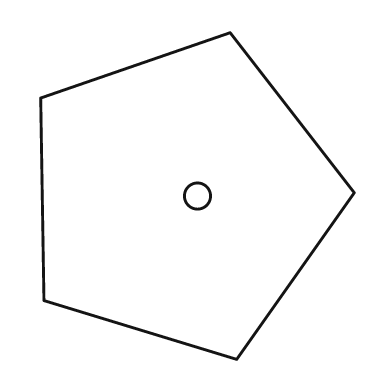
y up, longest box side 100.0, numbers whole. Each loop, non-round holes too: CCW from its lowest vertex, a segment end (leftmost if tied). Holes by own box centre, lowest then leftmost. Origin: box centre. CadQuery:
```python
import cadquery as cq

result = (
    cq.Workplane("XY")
    .moveTo(12.0, -50.0)
    .lineTo(48.0, 1.0)
    .lineTo(10.0, 50.0)
    .lineTo(-48.0, 30.0)
    .lineTo(-47.0, -32.0)
    .close()
    .moveTo(0.0, 0.0)
    .circle(4.0)
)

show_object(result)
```